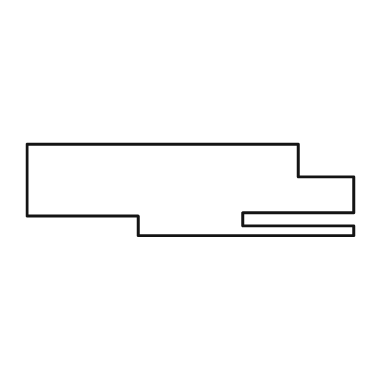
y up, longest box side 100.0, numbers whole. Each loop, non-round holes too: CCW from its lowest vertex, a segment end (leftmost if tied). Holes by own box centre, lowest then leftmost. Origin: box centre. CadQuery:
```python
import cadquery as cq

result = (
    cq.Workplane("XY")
    .moveTo(-16.0, -14.0)
    .lineTo(50.0, -14.0)
    .lineTo(50.0, -11.0)
    .lineTo(16.0, -11.0)
    .lineTo(16.0, -7.0)
    .lineTo(50.0, -7.0)
    .lineTo(50.0, 4.0)
    .lineTo(33.0, 4.0)
    .lineTo(33.0, 14.0)
    .lineTo(-50.0, 14.0)
    .lineTo(-50.0, -8.0)
    .lineTo(-16.0, -8.0)
    .close()
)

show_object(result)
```